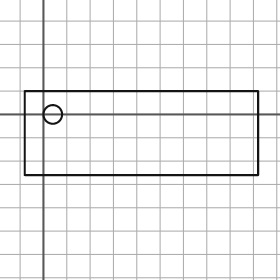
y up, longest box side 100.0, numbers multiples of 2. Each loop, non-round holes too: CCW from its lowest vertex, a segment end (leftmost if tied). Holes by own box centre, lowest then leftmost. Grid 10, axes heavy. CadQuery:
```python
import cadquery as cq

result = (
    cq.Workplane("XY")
    .moveTo(-8.0, -26.0)
    .lineTo(92.0, -26.0)
    .lineTo(92.0, 10.0)
    .lineTo(-8.0, 10.0)
    .close()
    .moveTo(4.0, 0.0)
    .circle(4.0)
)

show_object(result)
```